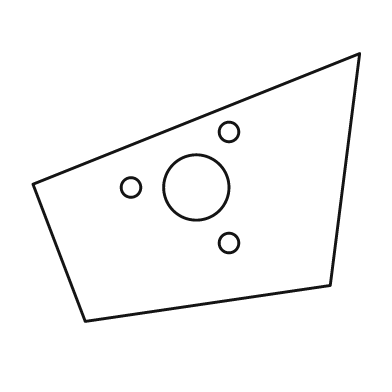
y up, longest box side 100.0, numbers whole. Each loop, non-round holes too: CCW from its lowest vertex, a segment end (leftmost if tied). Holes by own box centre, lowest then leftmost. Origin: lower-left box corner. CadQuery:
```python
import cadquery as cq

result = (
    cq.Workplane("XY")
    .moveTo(16.0, 0.0)
    .lineTo(91.0, 11.0)
    .lineTo(100.0, 82.0)
    .lineTo(0.0, 42.0)
    .close()
    .moveTo(60.0, 24.0)
    .circle(3.0)
    .moveTo(30.0, 41.0)
    .circle(3.0)
    .moveTo(50.0, 41.0)
    .circle(10.0)
    .moveTo(60.0, 58.0)
    .circle(3.0)
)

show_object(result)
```